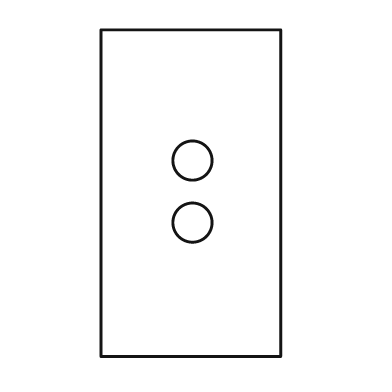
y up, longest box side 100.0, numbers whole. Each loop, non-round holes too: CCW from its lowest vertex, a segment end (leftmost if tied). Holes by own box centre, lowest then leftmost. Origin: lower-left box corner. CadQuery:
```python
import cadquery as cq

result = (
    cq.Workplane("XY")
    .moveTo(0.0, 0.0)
    .lineTo(55.0, 0.0)
    .lineTo(55.0, 100.0)
    .lineTo(0.0, 100.0)
    .close()
    .moveTo(28.0, 41.0)
    .circle(6.0)
    .moveTo(28.0, 60.0)
    .circle(6.0)
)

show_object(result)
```